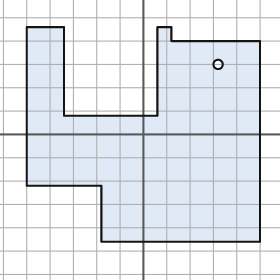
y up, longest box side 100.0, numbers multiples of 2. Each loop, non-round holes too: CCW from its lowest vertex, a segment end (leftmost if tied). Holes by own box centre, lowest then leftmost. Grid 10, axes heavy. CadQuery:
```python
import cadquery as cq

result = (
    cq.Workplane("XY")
    .moveTo(-18.0, -46.0)
    .lineTo(50.0, -46.0)
    .lineTo(50.0, 40.0)
    .lineTo(12.0, 40.0)
    .lineTo(12.0, 46.0)
    .lineTo(6.0, 46.0)
    .lineTo(6.0, 8.0)
    .lineTo(-34.0, 8.0)
    .lineTo(-34.0, 46.0)
    .lineTo(-50.0, 46.0)
    .lineTo(-50.0, -22.0)
    .lineTo(-18.0, -22.0)
    .close()
    .moveTo(32.0, 30.0)
    .circle(2.0)
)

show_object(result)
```